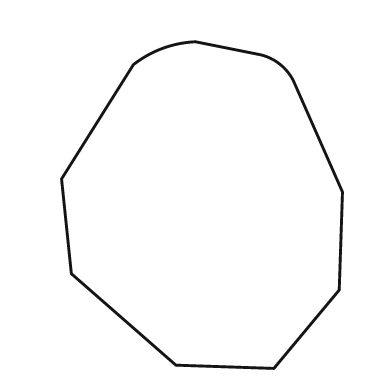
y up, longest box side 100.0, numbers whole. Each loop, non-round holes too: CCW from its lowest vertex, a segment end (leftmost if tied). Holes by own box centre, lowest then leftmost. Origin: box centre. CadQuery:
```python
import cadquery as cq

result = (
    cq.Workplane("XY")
    .moveTo(22.0, -50.0)
    .lineTo(42.0, -26.0)
    .lineTo(43.0, 4.0)
    .lineTo(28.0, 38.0)
    .threePointArc((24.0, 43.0), (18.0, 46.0))
    .lineTo(-2.0, 50.0)
    .threePointArc((-12.0, 48.0), (-21.0, 43.0))
    .lineTo(-43.0, 8.0)
    .lineTo(-40.0, -21.0)
    .lineTo(-8.0, -49.0)
    .close()
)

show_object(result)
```